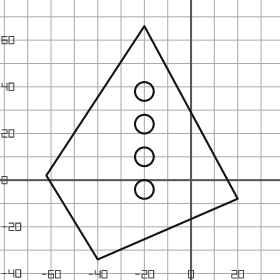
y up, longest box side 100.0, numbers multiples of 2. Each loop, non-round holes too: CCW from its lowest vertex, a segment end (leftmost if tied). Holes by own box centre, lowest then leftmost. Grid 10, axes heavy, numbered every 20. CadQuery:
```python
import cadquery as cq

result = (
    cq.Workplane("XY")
    .moveTo(-40.0, -34.0)
    .lineTo(20.0, -8.0)
    .lineTo(-20.0, 66.0)
    .lineTo(-62.0, 2.0)
    .close()
    .moveTo(-20.0, -4.0)
    .circle(4.0)
    .moveTo(-20.0, 10.0)
    .circle(4.0)
    .moveTo(-20.0, 24.0)
    .circle(4.0)
    .moveTo(-20.0, 38.0)
    .circle(4.0)
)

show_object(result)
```